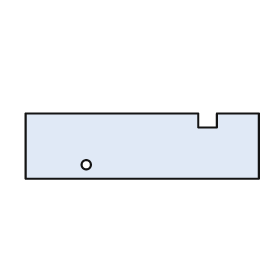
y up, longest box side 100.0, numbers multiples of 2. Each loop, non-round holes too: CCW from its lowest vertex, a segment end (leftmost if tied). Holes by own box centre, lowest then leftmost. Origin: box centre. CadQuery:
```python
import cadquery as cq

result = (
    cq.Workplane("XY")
    .moveTo(-50.0, -14.0)
    .lineTo(50.0, -14.0)
    .lineTo(50.0, 14.0)
    .lineTo(32.0, 14.0)
    .lineTo(32.0, 8.0)
    .lineTo(24.0, 8.0)
    .lineTo(24.0, 14.0)
    .lineTo(-50.0, 14.0)
    .close()
    .moveTo(-24.0, -8.0)
    .circle(2.0)
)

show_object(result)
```